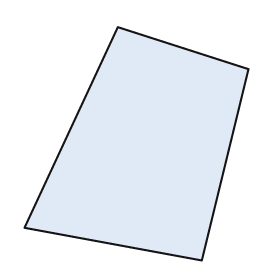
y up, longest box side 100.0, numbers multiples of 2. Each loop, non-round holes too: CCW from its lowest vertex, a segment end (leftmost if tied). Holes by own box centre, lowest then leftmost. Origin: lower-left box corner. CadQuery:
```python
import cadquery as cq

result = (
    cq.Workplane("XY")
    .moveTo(76.0, 0.0)
    .lineTo(96.0, 82.0)
    .lineTo(40.0, 100.0)
    .lineTo(0.0, 14.0)
    .close()
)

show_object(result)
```